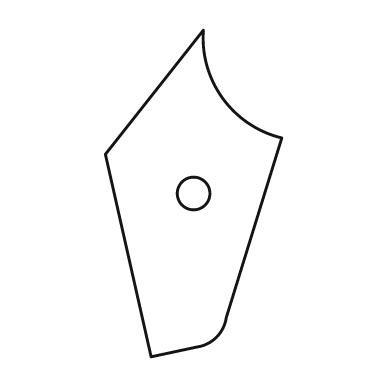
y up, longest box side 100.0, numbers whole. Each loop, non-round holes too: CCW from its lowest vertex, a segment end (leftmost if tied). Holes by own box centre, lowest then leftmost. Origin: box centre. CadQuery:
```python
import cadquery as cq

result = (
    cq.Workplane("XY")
    .moveTo(-13.0, -50.0)
    .lineTo(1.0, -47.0)
    .threePointArc((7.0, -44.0), (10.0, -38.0))
    .lineTo(27.0, 17.0)
    .threePointArc((9.0, 29.0), (3.0, 50.0))
    .lineTo(-27.0, 12.0)
    .close()
    .moveTo(0.0, 0.0)
    .circle(5.0)
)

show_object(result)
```